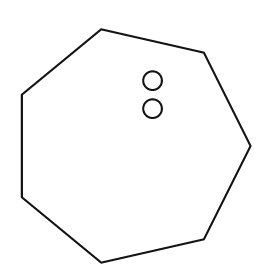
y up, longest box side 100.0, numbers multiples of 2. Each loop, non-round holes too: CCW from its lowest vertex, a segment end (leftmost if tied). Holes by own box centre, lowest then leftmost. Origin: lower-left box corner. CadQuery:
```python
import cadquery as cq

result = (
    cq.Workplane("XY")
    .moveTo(34.0, 0.0)
    .lineTo(78.0, 10.0)
    .lineTo(98.0, 50.0)
    .lineTo(78.0, 90.0)
    .lineTo(34.0, 100.0)
    .lineTo(0.0, 72.0)
    .lineTo(0.0, 28.0)
    .close()
    .moveTo(56.0, 66.0)
    .circle(4.0)
    .moveTo(56.0, 78.0)
    .circle(4.0)
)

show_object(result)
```